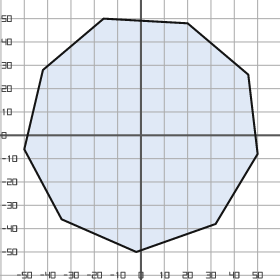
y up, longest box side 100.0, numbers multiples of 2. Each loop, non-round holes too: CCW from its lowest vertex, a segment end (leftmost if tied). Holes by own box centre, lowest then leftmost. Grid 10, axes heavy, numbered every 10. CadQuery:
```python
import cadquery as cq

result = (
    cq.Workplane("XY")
    .moveTo(-2.0, -50.0)
    .lineTo(32.0, -38.0)
    .lineTo(50.0, -8.0)
    .lineTo(46.0, 26.0)
    .lineTo(20.0, 48.0)
    .lineTo(-16.0, 50.0)
    .lineTo(-42.0, 28.0)
    .lineTo(-50.0, -6.0)
    .lineTo(-34.0, -36.0)
    .close()
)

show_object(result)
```